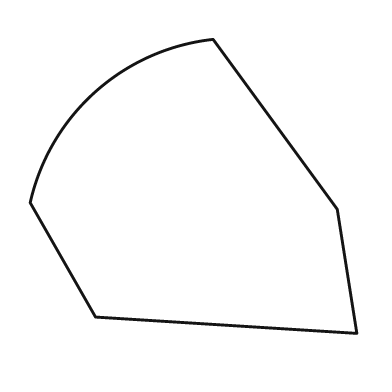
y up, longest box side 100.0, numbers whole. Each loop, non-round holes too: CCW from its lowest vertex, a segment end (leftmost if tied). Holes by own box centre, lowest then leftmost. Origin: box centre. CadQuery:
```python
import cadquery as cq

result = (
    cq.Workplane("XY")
    .moveTo(50.0, -45.0)
    .lineTo(44.0, -7.0)
    .lineTo(6.0, 45.0)
    .threePointArc((-30.0, 29.0), (-50.0, -5.0))
    .lineTo(-30.0, -40.0)
    .close()
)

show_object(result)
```